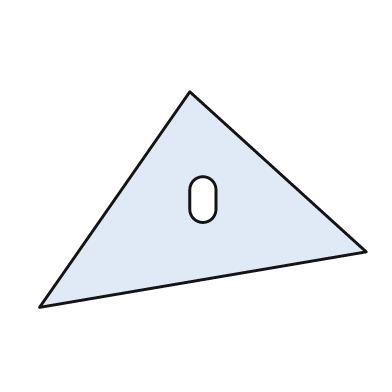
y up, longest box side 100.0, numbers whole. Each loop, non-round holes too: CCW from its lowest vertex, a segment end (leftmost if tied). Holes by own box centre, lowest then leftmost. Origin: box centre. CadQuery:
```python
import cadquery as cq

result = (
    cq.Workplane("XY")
    .moveTo(-50.0, -33.0)
    .lineTo(50.0, -16.0)
    .lineTo(-4.0, 33.0)
    .close()
    .moveTo(-4.0, -3.0)
    .threePointArc((0.0, -7.0), (4.0, -3.0))
    .lineTo(4.0, 3.0)
    .threePointArc((0.0, 7.0), (-4.0, 3.0))
    .close()
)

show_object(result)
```